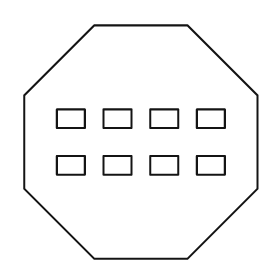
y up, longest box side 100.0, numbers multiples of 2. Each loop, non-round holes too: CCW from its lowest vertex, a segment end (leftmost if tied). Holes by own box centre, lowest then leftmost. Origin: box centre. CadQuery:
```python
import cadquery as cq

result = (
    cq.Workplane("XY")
    .moveTo(-20.0, -50.0)
    .lineTo(20.0, -50.0)
    .lineTo(50.0, -20.0)
    .lineTo(50.0, 20.0)
    .lineTo(20.0, 50.0)
    .lineTo(-20.0, 50.0)
    .lineTo(-50.0, 20.0)
    .lineTo(-50.0, -20.0)
    .close()
    .moveTo(-36.0, -14.0)
    .lineTo(-24.0, -14.0)
    .lineTo(-24.0, -6.0)
    .lineTo(-36.0, -6.0)
    .close()
    .moveTo(-16.0, -14.0)
    .lineTo(-4.0, -14.0)
    .lineTo(-4.0, -6.0)
    .lineTo(-16.0, -6.0)
    .close()
    .moveTo(4.0, -14.0)
    .lineTo(16.0, -14.0)
    .lineTo(16.0, -6.0)
    .lineTo(4.0, -6.0)
    .close()
    .moveTo(24.0, -14.0)
    .lineTo(36.0, -14.0)
    .lineTo(36.0, -6.0)
    .lineTo(24.0, -6.0)
    .close()
    .moveTo(-36.0, 6.0)
    .lineTo(-24.0, 6.0)
    .lineTo(-24.0, 14.0)
    .lineTo(-36.0, 14.0)
    .close()
    .moveTo(-16.0, 6.0)
    .lineTo(-4.0, 6.0)
    .lineTo(-4.0, 14.0)
    .lineTo(-16.0, 14.0)
    .close()
    .moveTo(4.0, 6.0)
    .lineTo(16.0, 6.0)
    .lineTo(16.0, 14.0)
    .lineTo(4.0, 14.0)
    .close()
    .moveTo(24.0, 6.0)
    .lineTo(36.0, 6.0)
    .lineTo(36.0, 14.0)
    .lineTo(24.0, 14.0)
    .close()
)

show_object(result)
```